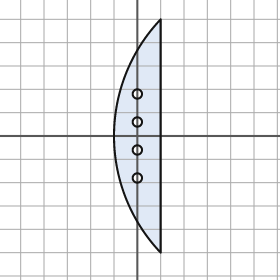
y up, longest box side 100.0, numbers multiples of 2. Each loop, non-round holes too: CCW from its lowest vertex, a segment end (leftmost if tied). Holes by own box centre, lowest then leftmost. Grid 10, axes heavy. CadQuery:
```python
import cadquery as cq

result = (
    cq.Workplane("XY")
    .moveTo(10.0, -50.0)
    .lineTo(10.0, 50.0)
    .threePointArc((-10.0, 0.0), (10.0, -50.0))
    .close()
    .moveTo(0.0, -18.0)
    .circle(2.0)
    .moveTo(0.0, -6.0)
    .circle(2.0)
    .moveTo(0.0, 6.0)
    .circle(2.0)
    .moveTo(0.0, 18.0)
    .circle(2.0)
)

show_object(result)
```